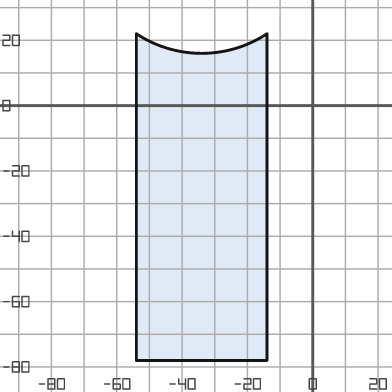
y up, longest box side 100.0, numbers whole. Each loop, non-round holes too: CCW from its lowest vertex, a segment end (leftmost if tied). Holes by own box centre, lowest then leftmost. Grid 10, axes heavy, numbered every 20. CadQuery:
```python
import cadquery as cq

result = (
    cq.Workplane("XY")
    .moveTo(-54.0, -78.0)
    .lineTo(-14.0, -78.0)
    .lineTo(-14.0, 22.0)
    .threePointArc((-34.0, 16.0), (-54.0, 22.0))
    .close()
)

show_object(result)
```